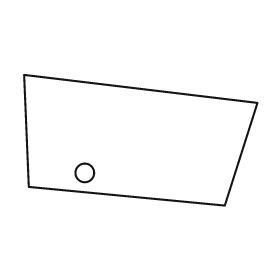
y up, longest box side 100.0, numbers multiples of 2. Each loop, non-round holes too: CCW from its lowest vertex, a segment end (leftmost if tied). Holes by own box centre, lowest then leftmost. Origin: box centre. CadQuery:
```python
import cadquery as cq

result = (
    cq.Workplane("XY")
    .moveTo(36.0, -28.0)
    .lineTo(50.0, 16.0)
    .lineTo(-50.0, 28.0)
    .lineTo(-48.0, -20.0)
    .close()
    .moveTo(-24.0, -14.0)
    .circle(4.0)
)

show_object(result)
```